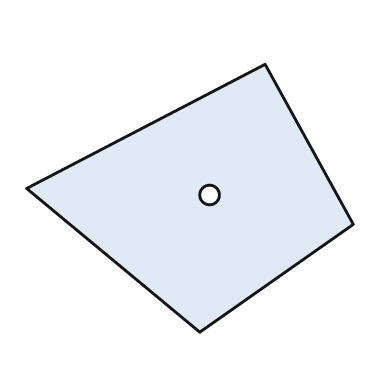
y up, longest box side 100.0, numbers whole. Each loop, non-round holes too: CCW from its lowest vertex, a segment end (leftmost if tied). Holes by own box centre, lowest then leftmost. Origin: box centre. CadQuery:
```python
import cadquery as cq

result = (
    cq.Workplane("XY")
    .moveTo(3.0, -41.0)
    .lineTo(50.0, -8.0)
    .lineTo(23.0, 41.0)
    .lineTo(-50.0, 3.0)
    .close()
    .moveTo(6.0, 1.0)
    .circle(3.0)
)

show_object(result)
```